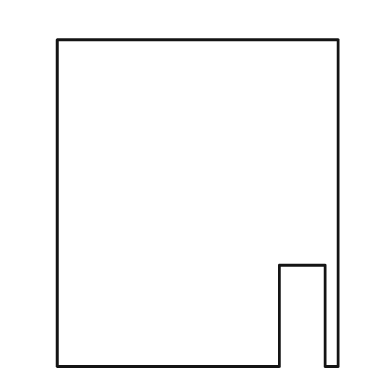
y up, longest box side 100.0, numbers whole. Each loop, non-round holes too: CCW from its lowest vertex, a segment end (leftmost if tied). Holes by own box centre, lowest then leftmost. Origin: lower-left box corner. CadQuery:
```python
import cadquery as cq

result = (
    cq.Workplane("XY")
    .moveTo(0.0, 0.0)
    .lineTo(68.0, 0.0)
    .lineTo(68.0, 31.0)
    .lineTo(82.0, 31.0)
    .lineTo(82.0, 0.0)
    .lineTo(86.0, 0.0)
    .lineTo(86.0, 100.0)
    .lineTo(0.0, 100.0)
    .close()
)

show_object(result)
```